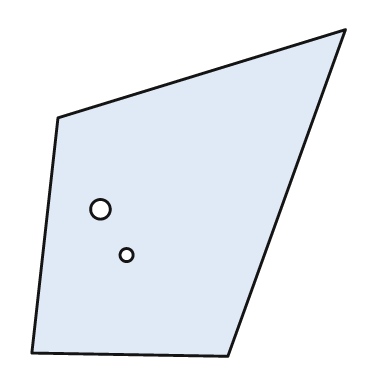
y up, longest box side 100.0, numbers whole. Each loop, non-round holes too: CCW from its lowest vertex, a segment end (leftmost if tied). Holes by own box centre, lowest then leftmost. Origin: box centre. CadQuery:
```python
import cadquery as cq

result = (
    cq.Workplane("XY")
    .moveTo(12.0, -50.0)
    .lineTo(48.0, 50.0)
    .lineTo(-40.0, 23.0)
    .lineTo(-48.0, -49.0)
    .close()
    .moveTo(-19.0, -19.0)
    .circle(2.0)
    .moveTo(-27.0, -5.0)
    .circle(3.0)
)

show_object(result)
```